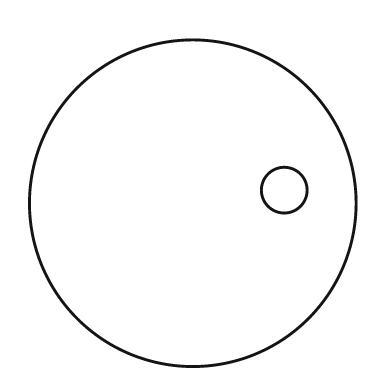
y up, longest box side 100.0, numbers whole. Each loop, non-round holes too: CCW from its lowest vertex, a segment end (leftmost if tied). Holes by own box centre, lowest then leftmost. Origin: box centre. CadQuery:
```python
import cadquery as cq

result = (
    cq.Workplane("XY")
    .moveTo(0.0, 0.0)
    .circle(50.0)
    .moveTo(28.0, 4.0)
    .circle(7.0)
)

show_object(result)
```